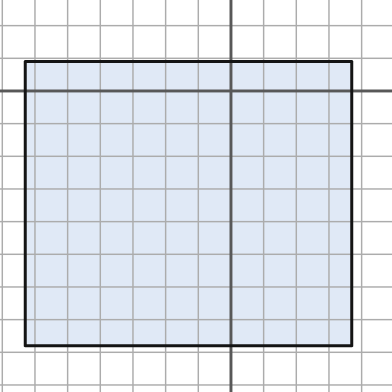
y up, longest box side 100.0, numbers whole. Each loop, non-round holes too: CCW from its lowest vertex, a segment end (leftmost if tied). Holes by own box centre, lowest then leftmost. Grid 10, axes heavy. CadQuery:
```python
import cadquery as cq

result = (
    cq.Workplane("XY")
    .moveTo(-63.0, -78.0)
    .lineTo(37.0, -78.0)
    .lineTo(37.0, 9.0)
    .lineTo(-63.0, 9.0)
    .close()
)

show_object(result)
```